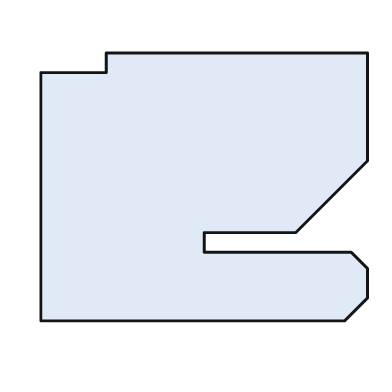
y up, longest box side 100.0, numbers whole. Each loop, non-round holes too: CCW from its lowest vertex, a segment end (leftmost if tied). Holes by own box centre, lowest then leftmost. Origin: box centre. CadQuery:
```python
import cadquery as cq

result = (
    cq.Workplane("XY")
    .moveTo(-50.0, -41.0)
    .lineTo(43.0, -41.0)
    .lineTo(50.0, -34.0)
    .lineTo(50.0, -25.0)
    .lineTo(45.0, -20.0)
    .lineTo(0.0, -20.0)
    .lineTo(0.0, -14.0)
    .lineTo(28.0, -14.0)
    .lineTo(50.0, 8.0)
    .lineTo(50.0, 41.0)
    .lineTo(-30.0, 41.0)
    .lineTo(-30.0, 35.0)
    .lineTo(-50.0, 35.0)
    .close()
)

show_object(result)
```